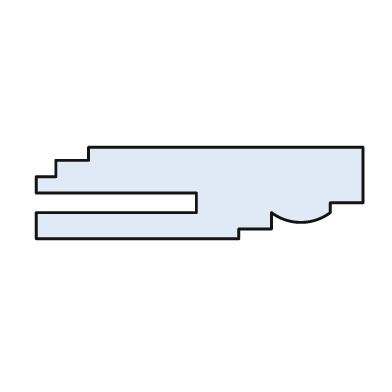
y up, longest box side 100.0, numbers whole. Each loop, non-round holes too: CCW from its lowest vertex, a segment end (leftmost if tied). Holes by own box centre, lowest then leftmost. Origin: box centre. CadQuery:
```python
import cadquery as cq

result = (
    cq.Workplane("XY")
    .moveTo(-50.0, -14.0)
    .lineTo(12.0, -14.0)
    .lineTo(12.0, -11.0)
    .lineTo(22.0, -11.0)
    .lineTo(22.0, -6.0)
    .threePointArc((31.0, -9.0), (40.0, -6.0))
    .lineTo(40.0, -3.0)
    .lineTo(50.0, -3.0)
    .lineTo(50.0, 14.0)
    .lineTo(-34.0, 14.0)
    .lineTo(-34.0, 10.0)
    .lineTo(-44.0, 10.0)
    .lineTo(-44.0, 5.0)
    .lineTo(-50.0, 5.0)
    .lineTo(-50.0, 0.0)
    .lineTo(-1.0, 0.0)
    .lineTo(-1.0, -6.0)
    .lineTo(-50.0, -6.0)
    .close()
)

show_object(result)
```